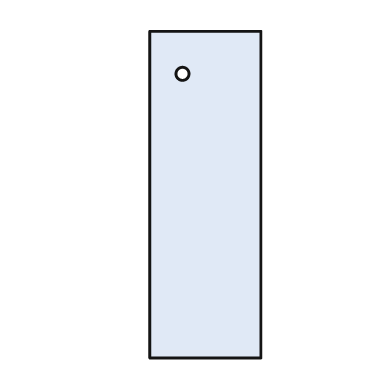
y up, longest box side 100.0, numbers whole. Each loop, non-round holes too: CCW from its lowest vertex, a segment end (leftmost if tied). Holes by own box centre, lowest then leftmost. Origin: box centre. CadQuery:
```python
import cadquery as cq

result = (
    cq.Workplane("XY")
    .moveTo(-17.0, -50.0)
    .lineTo(17.0, -50.0)
    .lineTo(17.0, 50.0)
    .lineTo(-17.0, 50.0)
    .close()
    .moveTo(-7.0, 37.0)
    .circle(2.0)
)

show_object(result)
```